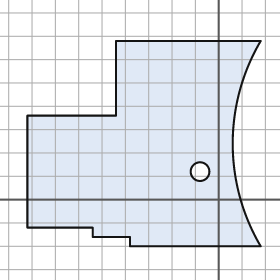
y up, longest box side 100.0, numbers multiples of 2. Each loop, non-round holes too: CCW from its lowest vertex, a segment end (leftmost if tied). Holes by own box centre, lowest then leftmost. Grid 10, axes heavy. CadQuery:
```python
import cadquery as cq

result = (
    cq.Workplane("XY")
    .moveTo(-38.0, -20.0)
    .lineTo(18.0, -20.0)
    .threePointArc((6.0, 24.0), (18.0, 68.0))
    .lineTo(-44.0, 68.0)
    .lineTo(-44.0, 36.0)
    .lineTo(-82.0, 36.0)
    .lineTo(-82.0, -12.0)
    .lineTo(-54.0, -12.0)
    .lineTo(-54.0, -16.0)
    .lineTo(-38.0, -16.0)
    .close()
    .moveTo(-8.0, 12.0)
    .circle(4.0)
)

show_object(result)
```